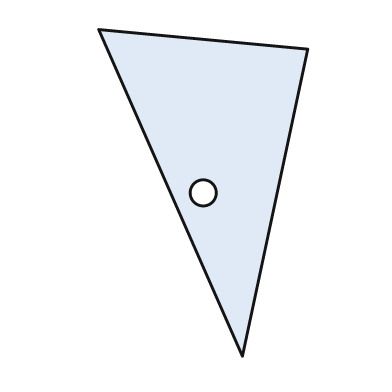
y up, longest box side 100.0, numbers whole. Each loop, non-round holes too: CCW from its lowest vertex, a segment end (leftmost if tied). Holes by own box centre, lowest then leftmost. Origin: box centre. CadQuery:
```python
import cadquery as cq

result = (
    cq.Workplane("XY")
    .moveTo(12.0, -50.0)
    .lineTo(32.0, 44.0)
    .lineTo(-32.0, 50.0)
    .close()
    .moveTo(0.0, 0.0)
    .circle(4.0)
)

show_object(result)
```